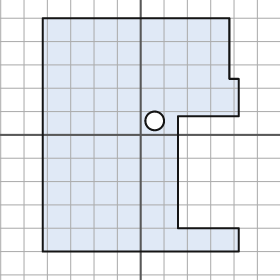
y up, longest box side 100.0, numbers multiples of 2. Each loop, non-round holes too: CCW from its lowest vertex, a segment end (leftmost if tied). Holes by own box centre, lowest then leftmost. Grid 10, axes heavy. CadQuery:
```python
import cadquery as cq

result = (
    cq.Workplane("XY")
    .moveTo(-42.0, -50.0)
    .lineTo(42.0, -50.0)
    .lineTo(42.0, -40.0)
    .lineTo(16.0, -40.0)
    .lineTo(16.0, 8.0)
    .lineTo(42.0, 8.0)
    .lineTo(42.0, 24.0)
    .lineTo(38.0, 24.0)
    .lineTo(38.0, 50.0)
    .lineTo(-42.0, 50.0)
    .close()
    .moveTo(6.0, 6.0)
    .circle(4.0)
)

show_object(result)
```